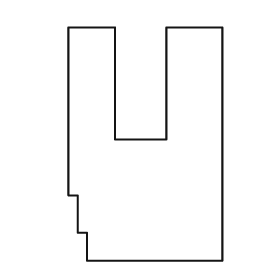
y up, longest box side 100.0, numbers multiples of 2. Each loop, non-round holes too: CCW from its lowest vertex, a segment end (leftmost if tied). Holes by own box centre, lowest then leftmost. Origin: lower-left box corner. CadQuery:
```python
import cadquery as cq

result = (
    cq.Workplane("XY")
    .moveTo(8.0, 0.0)
    .lineTo(66.0, 0.0)
    .lineTo(66.0, 100.0)
    .lineTo(42.0, 100.0)
    .lineTo(42.0, 52.0)
    .lineTo(20.0, 52.0)
    .lineTo(20.0, 100.0)
    .lineTo(0.0, 100.0)
    .lineTo(0.0, 28.0)
    .lineTo(4.0, 28.0)
    .lineTo(4.0, 12.0)
    .lineTo(8.0, 12.0)
    .close()
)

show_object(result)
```